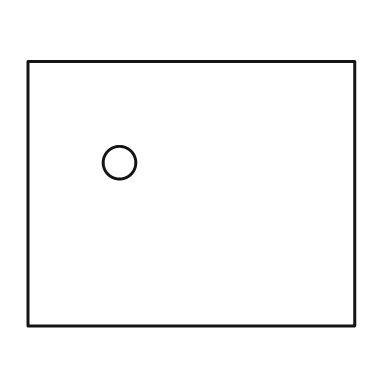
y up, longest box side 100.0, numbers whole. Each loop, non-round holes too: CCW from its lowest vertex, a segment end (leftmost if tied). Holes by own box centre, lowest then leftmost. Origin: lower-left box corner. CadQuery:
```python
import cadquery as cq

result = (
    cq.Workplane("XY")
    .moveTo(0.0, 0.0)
    .lineTo(100.0, 0.0)
    .lineTo(100.0, 81.0)
    .lineTo(0.0, 81.0)
    .close()
    .moveTo(28.0, 50.0)
    .circle(5.0)
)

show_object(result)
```